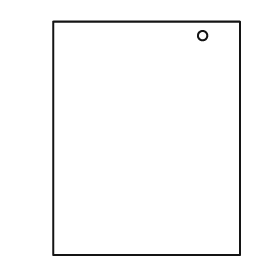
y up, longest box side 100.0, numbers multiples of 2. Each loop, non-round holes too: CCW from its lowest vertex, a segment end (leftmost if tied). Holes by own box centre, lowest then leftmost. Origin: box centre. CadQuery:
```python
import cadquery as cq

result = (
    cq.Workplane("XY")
    .moveTo(-40.0, -50.0)
    .lineTo(40.0, -50.0)
    .lineTo(40.0, 50.0)
    .lineTo(-40.0, 50.0)
    .close()
    .moveTo(24.0, 44.0)
    .circle(2.0)
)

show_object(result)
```